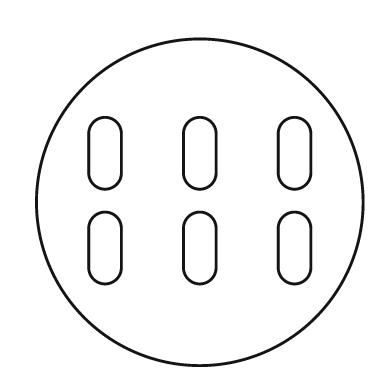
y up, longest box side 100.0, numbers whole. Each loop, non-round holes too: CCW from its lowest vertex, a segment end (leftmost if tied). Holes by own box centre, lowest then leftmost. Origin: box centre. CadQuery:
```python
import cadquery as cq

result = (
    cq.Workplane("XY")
    .moveTo(0.0, 0.0)
    .circle(50.0)
    .moveTo(-34.0, -20.0)
    .threePointArc((-29.0, -25.0), (-24.0, -20.0))
    .lineTo(-24.0, -8.0)
    .threePointArc((-29.0, -3.0), (-34.0, -8.0))
    .close()
    .moveTo(-5.0, -20.0)
    .threePointArc((0.0, -25.0), (5.0, -20.0))
    .lineTo(5.0, -8.0)
    .threePointArc((0.0, -3.0), (-5.0, -8.0))
    .close()
    .moveTo(24.0, -20.0)
    .threePointArc((29.0, -25.0), (34.0, -20.0))
    .lineTo(34.0, -8.0)
    .threePointArc((29.0, -3.0), (24.0, -8.0))
    .close()
    .moveTo(-34.0, 9.0)
    .threePointArc((-29.0, 4.0), (-24.0, 9.0))
    .lineTo(-24.0, 21.0)
    .threePointArc((-29.0, 26.0), (-34.0, 21.0))
    .close()
    .moveTo(-5.0, 9.0)
    .threePointArc((0.0, 4.0), (5.0, 9.0))
    .lineTo(5.0, 21.0)
    .threePointArc((0.0, 26.0), (-5.0, 21.0))
    .close()
    .moveTo(24.0, 9.0)
    .threePointArc((29.0, 4.0), (34.0, 9.0))
    .lineTo(34.0, 21.0)
    .threePointArc((29.0, 26.0), (24.0, 21.0))
    .close()
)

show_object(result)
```